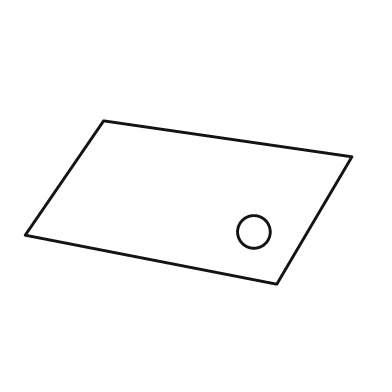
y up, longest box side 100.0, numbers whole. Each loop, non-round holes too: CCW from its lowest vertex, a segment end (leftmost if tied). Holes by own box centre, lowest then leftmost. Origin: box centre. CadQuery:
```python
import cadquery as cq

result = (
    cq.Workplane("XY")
    .moveTo(27.0, -25.0)
    .lineTo(50.0, 14.0)
    .lineTo(-26.0, 25.0)
    .lineTo(-50.0, -10.0)
    .close()
    .moveTo(20.0, -9.0)
    .circle(5.0)
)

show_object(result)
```